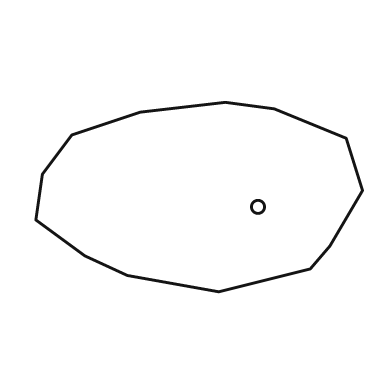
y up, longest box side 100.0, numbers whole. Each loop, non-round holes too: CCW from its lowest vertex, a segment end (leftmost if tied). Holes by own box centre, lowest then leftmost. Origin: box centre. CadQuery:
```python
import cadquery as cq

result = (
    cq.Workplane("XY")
    .moveTo(6.0, -29.0)
    .lineTo(34.0, -22.0)
    .lineTo(40.0, -15.0)
    .lineTo(50.0, 2.0)
    .lineTo(45.0, 18.0)
    .lineTo(23.0, 27.0)
    .lineTo(8.0, 29.0)
    .lineTo(-18.0, 26.0)
    .lineTo(-39.0, 19.0)
    .lineTo(-48.0, 7.0)
    .lineTo(-50.0, -7.0)
    .lineTo(-35.0, -18.0)
    .lineTo(-22.0, -24.0)
    .close()
    .moveTo(18.0, -3.0)
    .circle(2.0)
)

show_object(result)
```